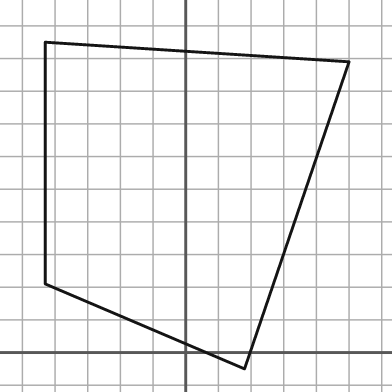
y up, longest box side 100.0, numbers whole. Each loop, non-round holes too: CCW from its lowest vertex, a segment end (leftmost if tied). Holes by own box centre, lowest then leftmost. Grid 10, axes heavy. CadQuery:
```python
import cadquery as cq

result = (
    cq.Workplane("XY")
    .moveTo(18.0, -5.0)
    .lineTo(50.0, 89.0)
    .lineTo(-43.0, 95.0)
    .lineTo(-43.0, 21.0)
    .close()
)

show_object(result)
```